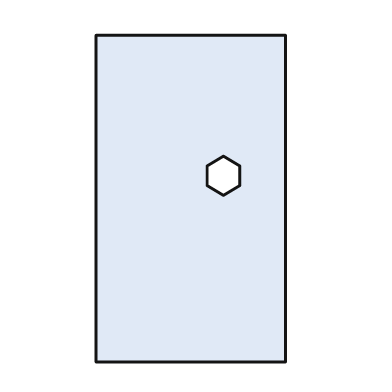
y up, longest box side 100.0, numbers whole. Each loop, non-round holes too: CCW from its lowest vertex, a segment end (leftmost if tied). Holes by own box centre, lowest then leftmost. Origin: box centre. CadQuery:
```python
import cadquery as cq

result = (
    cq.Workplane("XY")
    .moveTo(-29.0, -50.0)
    .lineTo(29.0, -50.0)
    .lineTo(29.0, 50.0)
    .lineTo(-29.0, 50.0)
    .close()
    .moveTo(10.0, 1.0)
    .lineTo(15.0, 4.0)
    .lineTo(15.0, 10.0)
    .lineTo(10.0, 13.0)
    .lineTo(5.0, 10.0)
    .lineTo(5.0, 4.0)
    .close()
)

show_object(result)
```